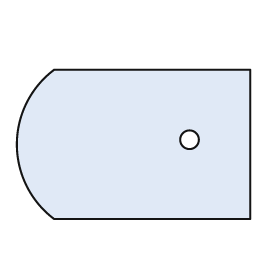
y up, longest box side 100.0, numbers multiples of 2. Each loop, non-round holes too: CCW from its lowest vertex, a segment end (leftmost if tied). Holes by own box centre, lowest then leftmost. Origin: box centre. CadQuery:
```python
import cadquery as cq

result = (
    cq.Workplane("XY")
    .moveTo(-34.0, -32.0)
    .lineTo(50.0, -32.0)
    .lineTo(50.0, 32.0)
    .lineTo(-34.0, 32.0)
    .threePointArc((-50.0, 0.0), (-34.0, -32.0))
    .close()
    .moveTo(24.0, 2.0)
    .circle(4.0)
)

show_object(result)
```